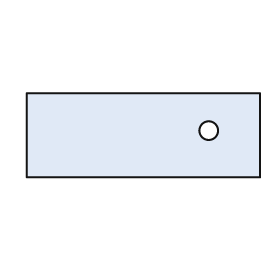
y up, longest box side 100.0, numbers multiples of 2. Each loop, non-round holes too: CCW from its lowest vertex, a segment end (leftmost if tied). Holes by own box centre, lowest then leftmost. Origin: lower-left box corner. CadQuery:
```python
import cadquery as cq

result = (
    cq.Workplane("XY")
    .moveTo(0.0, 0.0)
    .lineTo(100.0, 0.0)
    .lineTo(100.0, 36.0)
    .lineTo(0.0, 36.0)
    .close()
    .moveTo(78.0, 20.0)
    .circle(4.0)
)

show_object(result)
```